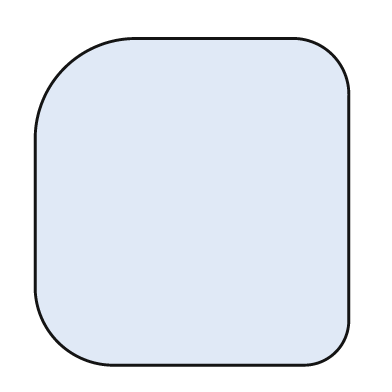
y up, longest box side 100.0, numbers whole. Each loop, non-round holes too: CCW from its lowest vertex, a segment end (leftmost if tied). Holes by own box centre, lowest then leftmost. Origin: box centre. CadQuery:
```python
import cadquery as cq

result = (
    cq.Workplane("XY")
    .moveTo(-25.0, -50.0)
    .lineTo(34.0, -50.0)
    .threePointArc((44.0, -46.0), (48.0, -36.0))
    .lineTo(48.0, 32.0)
    .threePointArc((43.0, 45.0), (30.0, 50.0))
    .lineTo(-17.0, 50.0)
    .threePointArc((-39.0, 41.0), (-48.0, 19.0))
    .lineTo(-48.0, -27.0)
    .threePointArc((-41.0, -43.0), (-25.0, -50.0))
    .close()
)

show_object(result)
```